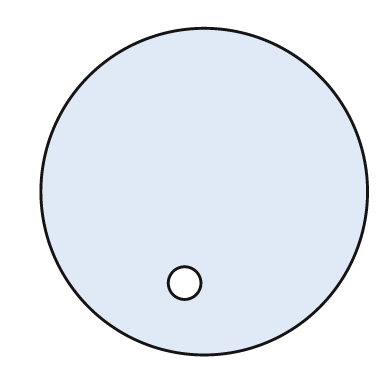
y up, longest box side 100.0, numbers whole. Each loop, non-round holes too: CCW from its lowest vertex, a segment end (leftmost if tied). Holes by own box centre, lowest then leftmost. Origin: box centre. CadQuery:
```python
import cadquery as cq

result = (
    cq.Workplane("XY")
    .moveTo(0.0, 0.0)
    .circle(50.0)
    .moveTo(-6.0, -28.0)
    .circle(5.0)
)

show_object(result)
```